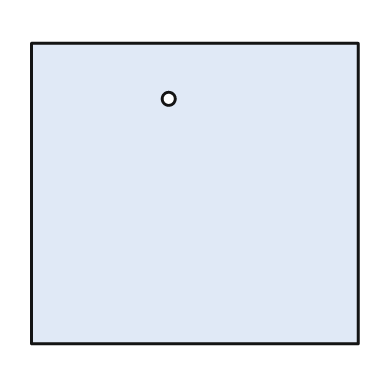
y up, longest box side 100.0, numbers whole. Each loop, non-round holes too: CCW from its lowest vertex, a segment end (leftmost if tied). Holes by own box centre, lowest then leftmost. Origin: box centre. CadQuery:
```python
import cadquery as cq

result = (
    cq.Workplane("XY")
    .moveTo(-50.0, -46.0)
    .lineTo(50.0, -46.0)
    .lineTo(50.0, 46.0)
    .lineTo(-50.0, 46.0)
    .close()
    .moveTo(-8.0, 29.0)
    .circle(2.0)
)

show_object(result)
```